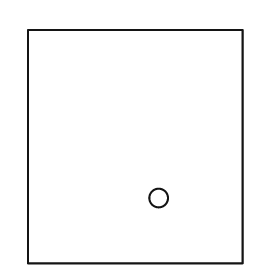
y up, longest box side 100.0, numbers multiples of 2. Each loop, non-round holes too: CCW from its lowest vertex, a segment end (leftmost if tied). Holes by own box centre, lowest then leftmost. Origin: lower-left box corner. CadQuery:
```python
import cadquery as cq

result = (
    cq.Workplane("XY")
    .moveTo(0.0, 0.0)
    .lineTo(92.0, 0.0)
    .lineTo(92.0, 100.0)
    .lineTo(0.0, 100.0)
    .close()
    .moveTo(56.0, 28.0)
    .circle(4.0)
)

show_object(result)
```